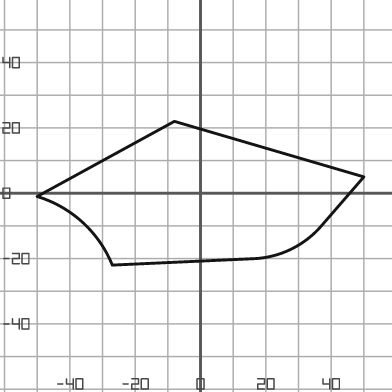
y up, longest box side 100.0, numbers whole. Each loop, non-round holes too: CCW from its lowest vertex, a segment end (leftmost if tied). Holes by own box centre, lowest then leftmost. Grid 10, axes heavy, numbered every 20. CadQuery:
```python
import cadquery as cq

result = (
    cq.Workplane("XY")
    .moveTo(-27.0, -22.0)
    .lineTo(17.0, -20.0)
    .threePointArc((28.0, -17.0), (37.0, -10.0))
    .lineTo(50.0, 5.0)
    .lineTo(-8.0, 22.0)
    .lineTo(-50.0, -1.0)
    .threePointArc((-36.0, -9.0), (-27.0, -22.0))
    .close()
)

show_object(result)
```